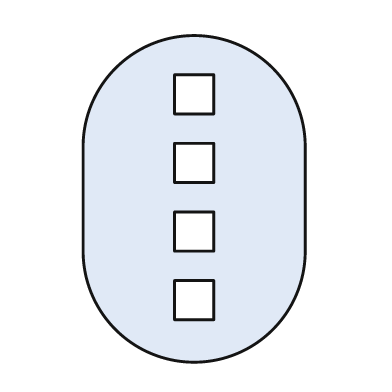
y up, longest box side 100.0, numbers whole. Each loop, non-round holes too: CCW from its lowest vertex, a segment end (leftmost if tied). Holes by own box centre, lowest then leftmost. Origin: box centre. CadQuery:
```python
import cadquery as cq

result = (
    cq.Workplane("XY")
    .moveTo(-34.0, -16.0)
    .threePointArc((0.0, -50.0), (34.0, -16.0))
    .lineTo(34.0, 16.0)
    .threePointArc((0.0, 50.0), (-34.0, 16.0))
    .close()
    .moveTo(-6.0, -37.0)
    .lineTo(6.0, -37.0)
    .lineTo(6.0, -25.0)
    .lineTo(-6.0, -25.0)
    .close()
    .moveTo(-6.0, -16.0)
    .lineTo(6.0, -16.0)
    .lineTo(6.0, -4.0)
    .lineTo(-6.0, -4.0)
    .close()
    .moveTo(-6.0, 5.0)
    .lineTo(6.0, 5.0)
    .lineTo(6.0, 17.0)
    .lineTo(-6.0, 17.0)
    .close()
    .moveTo(-6.0, 26.0)
    .lineTo(6.0, 26.0)
    .lineTo(6.0, 38.0)
    .lineTo(-6.0, 38.0)
    .close()
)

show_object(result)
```